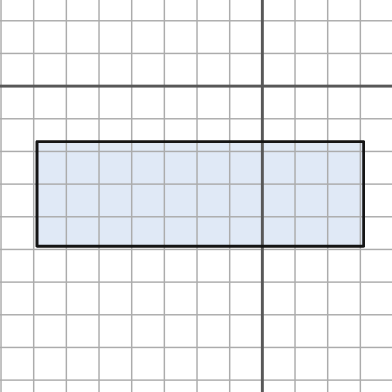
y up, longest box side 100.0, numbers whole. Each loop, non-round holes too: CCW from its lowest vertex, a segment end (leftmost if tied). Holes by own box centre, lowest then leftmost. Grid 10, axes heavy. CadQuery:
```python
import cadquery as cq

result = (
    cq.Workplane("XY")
    .moveTo(-69.0, -49.0)
    .lineTo(31.0, -49.0)
    .lineTo(31.0, -17.0)
    .lineTo(-69.0, -17.0)
    .close()
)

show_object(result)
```